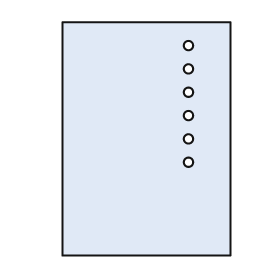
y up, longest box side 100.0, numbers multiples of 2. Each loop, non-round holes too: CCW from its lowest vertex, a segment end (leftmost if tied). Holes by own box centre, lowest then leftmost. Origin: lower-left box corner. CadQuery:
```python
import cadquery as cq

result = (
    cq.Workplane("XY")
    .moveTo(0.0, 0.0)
    .lineTo(72.0, 0.0)
    .lineTo(72.0, 100.0)
    .lineTo(0.0, 100.0)
    .close()
    .moveTo(54.0, 40.0)
    .circle(2.0)
    .moveTo(54.0, 50.0)
    .circle(2.0)
    .moveTo(54.0, 60.0)
    .circle(2.0)
    .moveTo(54.0, 70.0)
    .circle(2.0)
    .moveTo(54.0, 80.0)
    .circle(2.0)
    .moveTo(54.0, 90.0)
    .circle(2.0)
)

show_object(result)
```